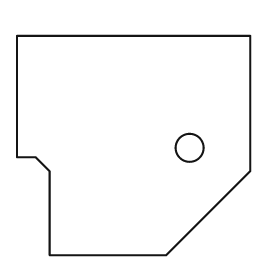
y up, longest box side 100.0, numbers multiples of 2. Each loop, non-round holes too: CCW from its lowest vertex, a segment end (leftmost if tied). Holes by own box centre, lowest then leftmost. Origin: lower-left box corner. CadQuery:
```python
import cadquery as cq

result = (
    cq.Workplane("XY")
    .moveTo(14.0, 0.0)
    .lineTo(64.0, 0.0)
    .lineTo(100.0, 36.0)
    .lineTo(100.0, 94.0)
    .lineTo(0.0, 94.0)
    .lineTo(0.0, 42.0)
    .lineTo(8.0, 42.0)
    .lineTo(14.0, 36.0)
    .close()
    .moveTo(74.0, 46.0)
    .circle(6.0)
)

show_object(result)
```